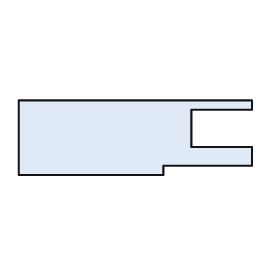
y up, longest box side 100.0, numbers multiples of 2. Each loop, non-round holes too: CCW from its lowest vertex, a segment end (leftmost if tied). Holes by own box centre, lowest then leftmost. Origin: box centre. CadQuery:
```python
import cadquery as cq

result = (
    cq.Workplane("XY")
    .moveTo(-50.0, -16.0)
    .lineTo(12.0, -16.0)
    .lineTo(12.0, -12.0)
    .lineTo(50.0, -12.0)
    .lineTo(50.0, -4.0)
    .lineTo(24.0, -4.0)
    .lineTo(24.0, 12.0)
    .lineTo(50.0, 12.0)
    .lineTo(50.0, 16.0)
    .lineTo(-50.0, 16.0)
    .close()
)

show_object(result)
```